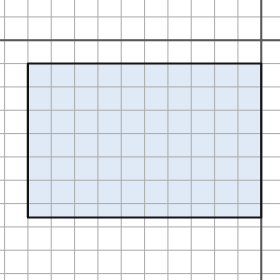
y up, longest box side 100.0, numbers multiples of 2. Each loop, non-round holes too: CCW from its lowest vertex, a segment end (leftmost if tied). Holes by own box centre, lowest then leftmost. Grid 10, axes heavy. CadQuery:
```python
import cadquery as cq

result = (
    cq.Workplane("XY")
    .moveTo(-100.0, -76.0)
    .lineTo(0.0, -76.0)
    .lineTo(0.0, -10.0)
    .lineTo(-100.0, -10.0)
    .close()
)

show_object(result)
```